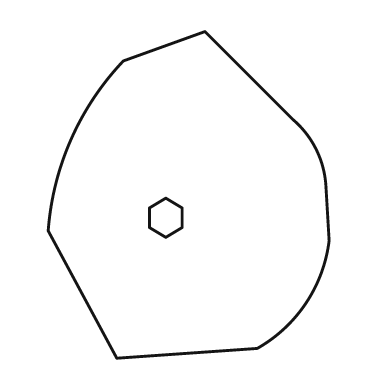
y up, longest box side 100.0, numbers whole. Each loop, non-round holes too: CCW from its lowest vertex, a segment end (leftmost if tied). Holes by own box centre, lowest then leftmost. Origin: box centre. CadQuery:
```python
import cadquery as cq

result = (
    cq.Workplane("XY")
    .moveTo(-22.0, -50.0)
    .lineTo(21.0, -47.0)
    .threePointArc((36.0, -33.0), (43.0, -14.0))
    .lineTo(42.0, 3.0)
    .threePointArc((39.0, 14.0), (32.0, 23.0))
    .lineTo(5.0, 50.0)
    .lineTo(-20.0, 41.0)
    .threePointArc((-36.0, 17.0), (-43.0, -11.0))
    .close()
    .moveTo(-7.0, -13.0)
    .lineTo(-2.0, -10.0)
    .lineTo(-2.0, -4.0)
    .lineTo(-7.0, -1.0)
    .lineTo(-12.0, -4.0)
    .lineTo(-12.0, -10.0)
    .close()
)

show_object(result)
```